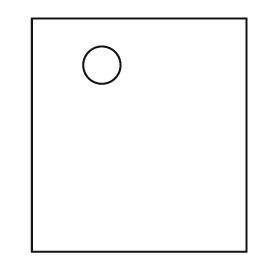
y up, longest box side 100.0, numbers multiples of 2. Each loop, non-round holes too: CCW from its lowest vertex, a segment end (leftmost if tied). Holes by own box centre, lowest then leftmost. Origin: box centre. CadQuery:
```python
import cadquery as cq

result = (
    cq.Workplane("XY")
    .moveTo(-46.0, -50.0)
    .lineTo(46.0, -50.0)
    .lineTo(46.0, 50.0)
    .lineTo(-46.0, 50.0)
    .close()
    .moveTo(-16.0, 30.0)
    .circle(8.0)
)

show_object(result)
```